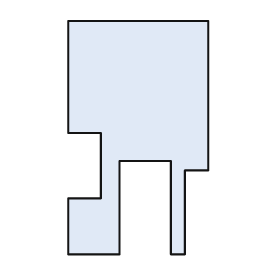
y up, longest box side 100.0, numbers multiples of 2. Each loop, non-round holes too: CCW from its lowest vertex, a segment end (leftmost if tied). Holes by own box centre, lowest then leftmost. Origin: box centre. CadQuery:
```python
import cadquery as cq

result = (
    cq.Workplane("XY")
    .moveTo(-30.0, -50.0)
    .lineTo(-8.0, -50.0)
    .lineTo(-8.0, -10.0)
    .lineTo(14.0, -10.0)
    .lineTo(14.0, -50.0)
    .lineTo(20.0, -50.0)
    .lineTo(20.0, -14.0)
    .lineTo(30.0, -14.0)
    .lineTo(30.0, 50.0)
    .lineTo(-30.0, 50.0)
    .lineTo(-30.0, 2.0)
    .lineTo(-16.0, 2.0)
    .lineTo(-16.0, -26.0)
    .lineTo(-30.0, -26.0)
    .close()
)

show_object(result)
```